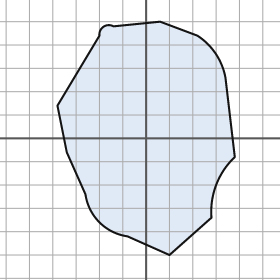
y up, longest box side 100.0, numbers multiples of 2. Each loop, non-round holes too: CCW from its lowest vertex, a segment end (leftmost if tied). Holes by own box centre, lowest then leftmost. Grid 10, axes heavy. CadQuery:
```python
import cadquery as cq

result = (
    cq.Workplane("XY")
    .moveTo(10.0, -50.0)
    .lineTo(28.0, -34.0)
    .threePointArc((30.0, -20.0), (38.0, -8.0))
    .lineTo(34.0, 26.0)
    .threePointArc((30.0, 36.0), (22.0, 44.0))
    .lineTo(6.0, 50.0)
    .lineTo(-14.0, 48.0)
    .threePointArc((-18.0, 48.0), (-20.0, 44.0))
    .lineTo(-38.0, 14.0)
    .lineTo(-34.0, -6.0)
    .lineTo(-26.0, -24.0)
    .threePointArc((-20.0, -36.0), (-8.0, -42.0))
    .close()
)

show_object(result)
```